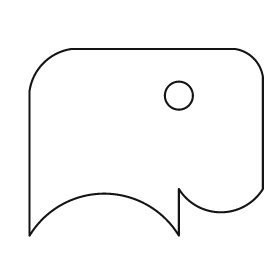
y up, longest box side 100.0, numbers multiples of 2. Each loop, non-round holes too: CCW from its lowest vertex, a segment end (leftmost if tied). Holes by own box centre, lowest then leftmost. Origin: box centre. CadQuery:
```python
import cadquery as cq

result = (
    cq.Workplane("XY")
    .moveTo(-50.0, -40.0)
    .threePointArc((-18.0, -22.0), (14.0, -40.0))
    .lineTo(14.0, -20.0)
    .threePointArc((32.0, -30.0), (50.0, -20.0))
    .lineTo(50.0, 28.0)
    .threePointArc((46.0, 36.0), (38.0, 40.0))
    .lineTo(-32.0, 40.0)
    .threePointArc((-44.0, 34.0), (-50.0, 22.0))
    .close()
    .moveTo(14.0, 20.0)
    .circle(6.0)
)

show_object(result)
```